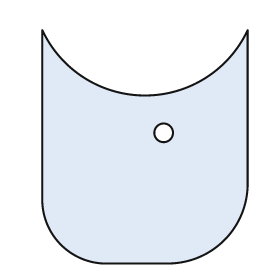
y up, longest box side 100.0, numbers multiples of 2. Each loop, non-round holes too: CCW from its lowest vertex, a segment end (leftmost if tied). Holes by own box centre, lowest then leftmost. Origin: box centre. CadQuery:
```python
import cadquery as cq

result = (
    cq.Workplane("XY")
    .moveTo(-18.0, -50.0)
    .lineTo(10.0, -50.0)
    .threePointArc((34.0, -40.0), (44.0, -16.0))
    .lineTo(44.0, 50.0)
    .threePointArc((0.0, 22.0), (-44.0, 50.0))
    .lineTo(-44.0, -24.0)
    .threePointArc((-36.0, -42.0), (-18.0, -50.0))
    .close()
    .moveTo(8.0, 6.0)
    .circle(4.0)
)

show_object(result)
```